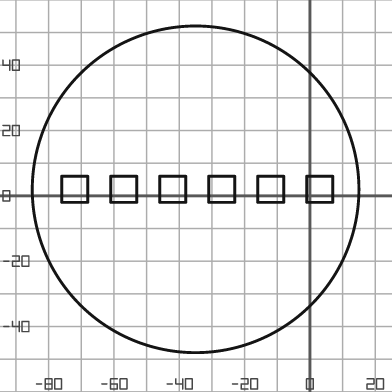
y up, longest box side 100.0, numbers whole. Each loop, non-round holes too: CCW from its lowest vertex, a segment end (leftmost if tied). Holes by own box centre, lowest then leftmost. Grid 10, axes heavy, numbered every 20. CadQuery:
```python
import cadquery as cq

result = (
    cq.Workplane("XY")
    .moveTo(-35.0, 2.0)
    .circle(50.0)
    .moveTo(-76.0, -2.0)
    .lineTo(-68.0, -2.0)
    .lineTo(-68.0, 6.0)
    .lineTo(-76.0, 6.0)
    .close()
    .moveTo(-61.0, -2.0)
    .lineTo(-53.0, -2.0)
    .lineTo(-53.0, 6.0)
    .lineTo(-61.0, 6.0)
    .close()
    .moveTo(-46.0, -2.0)
    .lineTo(-38.0, -2.0)
    .lineTo(-38.0, 6.0)
    .lineTo(-46.0, 6.0)
    .close()
    .moveTo(-31.0, -2.0)
    .lineTo(-23.0, -2.0)
    .lineTo(-23.0, 6.0)
    .lineTo(-31.0, 6.0)
    .close()
    .moveTo(-16.0, -2.0)
    .lineTo(-8.0, -2.0)
    .lineTo(-8.0, 6.0)
    .lineTo(-16.0, 6.0)
    .close()
    .moveTo(-1.0, -2.0)
    .lineTo(7.0, -2.0)
    .lineTo(7.0, 6.0)
    .lineTo(-1.0, 6.0)
    .close()
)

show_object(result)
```